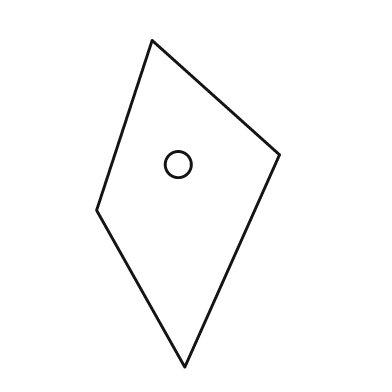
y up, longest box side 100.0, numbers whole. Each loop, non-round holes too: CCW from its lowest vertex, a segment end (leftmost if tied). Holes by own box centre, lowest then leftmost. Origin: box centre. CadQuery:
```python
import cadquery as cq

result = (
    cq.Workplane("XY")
    .moveTo(-1.0, -50.0)
    .lineTo(28.0, 15.0)
    .lineTo(-11.0, 50.0)
    .lineTo(-28.0, -2.0)
    .close()
    .moveTo(-3.0, 12.0)
    .circle(4.0)
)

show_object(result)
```